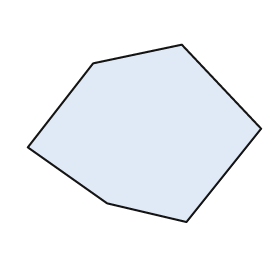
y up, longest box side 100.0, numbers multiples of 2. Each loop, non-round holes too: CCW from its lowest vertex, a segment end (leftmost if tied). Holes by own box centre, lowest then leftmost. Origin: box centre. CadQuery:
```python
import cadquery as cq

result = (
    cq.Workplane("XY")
    .moveTo(18.0, -38.0)
    .lineTo(50.0, 2.0)
    .lineTo(16.0, 38.0)
    .lineTo(-22.0, 30.0)
    .lineTo(-50.0, -6.0)
    .lineTo(-16.0, -30.0)
    .close()
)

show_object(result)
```